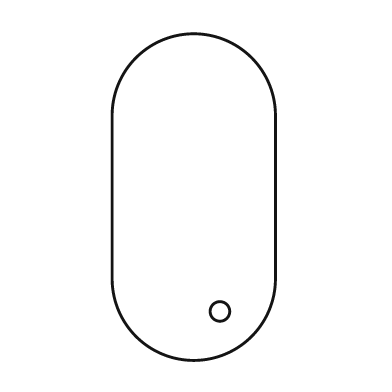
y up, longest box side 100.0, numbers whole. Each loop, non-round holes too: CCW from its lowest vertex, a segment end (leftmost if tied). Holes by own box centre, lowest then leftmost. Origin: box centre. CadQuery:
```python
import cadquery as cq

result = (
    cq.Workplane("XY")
    .moveTo(-25.0, -25.0)
    .threePointArc((0.0, -50.0), (25.0, -25.0))
    .lineTo(25.0, 25.0)
    .threePointArc((0.0, 50.0), (-25.0, 25.0))
    .close()
    .moveTo(8.0, -35.0)
    .circle(3.0)
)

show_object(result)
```